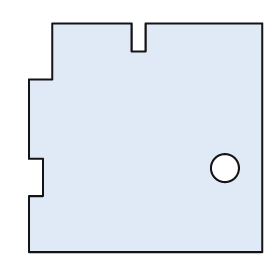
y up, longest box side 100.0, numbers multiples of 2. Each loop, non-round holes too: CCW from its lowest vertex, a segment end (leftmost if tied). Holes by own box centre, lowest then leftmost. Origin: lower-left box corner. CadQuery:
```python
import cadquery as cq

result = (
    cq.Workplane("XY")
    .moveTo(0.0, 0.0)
    .lineTo(100.0, 0.0)
    .lineTo(100.0, 98.0)
    .lineTo(50.0, 98.0)
    .lineTo(50.0, 86.0)
    .lineTo(44.0, 86.0)
    .lineTo(44.0, 98.0)
    .lineTo(10.0, 98.0)
    .lineTo(10.0, 74.0)
    .lineTo(0.0, 74.0)
    .lineTo(0.0, 40.0)
    .lineTo(6.0, 40.0)
    .lineTo(6.0, 24.0)
    .lineTo(0.0, 24.0)
    .close()
    .moveTo(84.0, 36.0)
    .circle(6.0)
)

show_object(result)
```